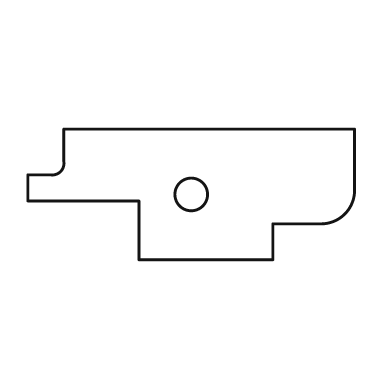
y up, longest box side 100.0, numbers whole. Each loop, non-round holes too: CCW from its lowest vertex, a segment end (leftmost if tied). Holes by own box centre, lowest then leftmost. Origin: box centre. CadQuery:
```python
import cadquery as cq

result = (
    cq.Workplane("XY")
    .moveTo(-16.0, -20.0)
    .lineTo(25.0, -20.0)
    .lineTo(25.0, -9.0)
    .lineTo(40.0, -9.0)
    .threePointArc((47.0, -6.0), (50.0, 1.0))
    .lineTo(50.0, 20.0)
    .lineTo(-39.0, 20.0)
    .lineTo(-39.0, 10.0)
    .threePointArc((-40.0, 7.0), (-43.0, 6.0))
    .lineTo(-50.0, 6.0)
    .lineTo(-50.0, -2.0)
    .lineTo(-16.0, -2.0)
    .close()
    .moveTo(0.0, 0.0)
    .circle(5.0)
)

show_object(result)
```